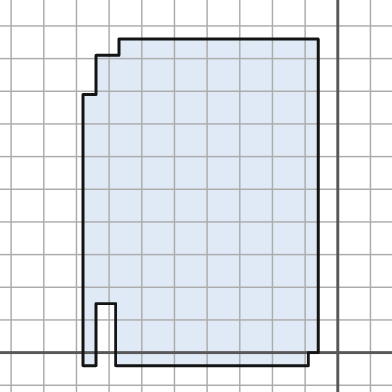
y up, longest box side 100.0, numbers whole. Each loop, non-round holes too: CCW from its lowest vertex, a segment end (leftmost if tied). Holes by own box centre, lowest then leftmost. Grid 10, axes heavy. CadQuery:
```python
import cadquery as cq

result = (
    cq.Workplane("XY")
    .moveTo(-78.0, -4.0)
    .lineTo(-74.0, -4.0)
    .lineTo(-74.0, 15.0)
    .lineTo(-68.0, 15.0)
    .lineTo(-68.0, -4.0)
    .lineTo(-9.0, -4.0)
    .lineTo(-9.0, 0.0)
    .lineTo(-6.0, 0.0)
    .lineTo(-6.0, 96.0)
    .lineTo(-67.0, 96.0)
    .lineTo(-67.0, 91.0)
    .lineTo(-74.0, 91.0)
    .lineTo(-74.0, 79.0)
    .lineTo(-78.0, 79.0)
    .close()
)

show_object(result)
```